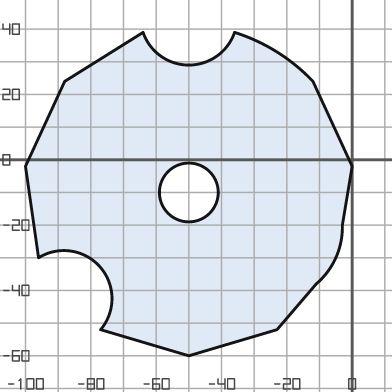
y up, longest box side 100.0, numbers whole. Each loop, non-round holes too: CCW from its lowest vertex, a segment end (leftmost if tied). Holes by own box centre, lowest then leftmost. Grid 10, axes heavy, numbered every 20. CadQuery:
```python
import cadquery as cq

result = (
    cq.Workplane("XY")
    .moveTo(-50.0, -60.0)
    .lineTo(-23.0, -52.0)
    .lineTo(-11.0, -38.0)
    .threePointArc((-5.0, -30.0), (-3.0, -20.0))
    .lineTo(0.0, -2.0)
    .lineTo(-12.0, 24.0)
    .threePointArc((-23.0, 33.0), (-36.0, 39.0))
    .threePointArc((-50.0, 29.0), (-64.0, 39.0))
    .lineTo(-88.0, 24.0)
    .lineTo(-100.0, -2.0)
    .lineTo(-96.0, -30.0)
    .threePointArc((-77.0, -33.0), (-77.0, -52.0))
    .close()
    .moveTo(-50.0, -10.0)
    .circle(9.0)
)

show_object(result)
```